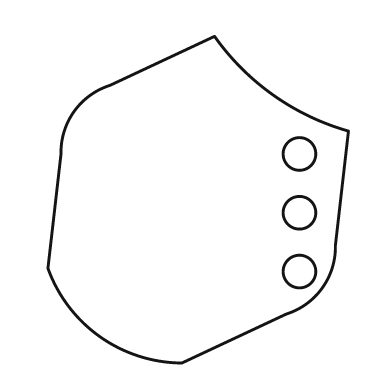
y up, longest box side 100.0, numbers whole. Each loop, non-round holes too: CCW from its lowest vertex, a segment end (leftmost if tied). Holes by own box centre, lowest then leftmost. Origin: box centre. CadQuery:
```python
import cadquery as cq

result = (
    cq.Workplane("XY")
    .moveTo(-5.0, -50.0)
    .lineTo(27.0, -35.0)
    .threePointArc((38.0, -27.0), (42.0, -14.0))
    .lineTo(46.0, 21.0)
    .threePointArc((23.0, 32.0), (5.0, 50.0))
    .lineTo(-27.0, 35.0)
    .threePointArc((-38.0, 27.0), (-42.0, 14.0))
    .lineTo(-46.0, -21.0)
    .threePointArc((-30.0, -42.0), (-5.0, -50.0))
    .close()
    .moveTo(31.0, -22.0)
    .circle(5.0)
    .moveTo(31.0, -4.0)
    .circle(5.0)
    .moveTo(31.0, 14.0)
    .circle(5.0)
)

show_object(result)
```